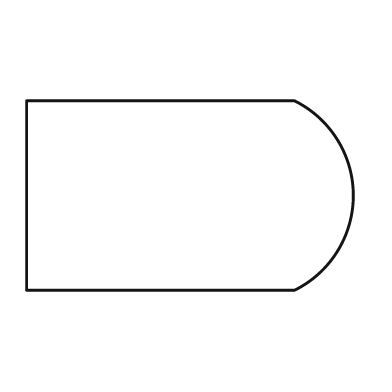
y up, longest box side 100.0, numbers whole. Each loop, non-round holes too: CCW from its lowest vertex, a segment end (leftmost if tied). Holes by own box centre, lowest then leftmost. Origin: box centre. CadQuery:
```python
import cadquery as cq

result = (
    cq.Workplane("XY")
    .moveTo(-50.0, -29.0)
    .lineTo(32.0, -29.0)
    .threePointArc((50.0, 0.0), (32.0, 29.0))
    .lineTo(-50.0, 29.0)
    .close()
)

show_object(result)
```